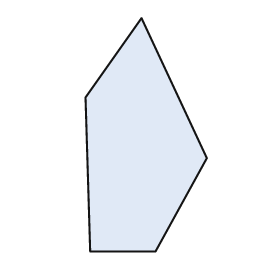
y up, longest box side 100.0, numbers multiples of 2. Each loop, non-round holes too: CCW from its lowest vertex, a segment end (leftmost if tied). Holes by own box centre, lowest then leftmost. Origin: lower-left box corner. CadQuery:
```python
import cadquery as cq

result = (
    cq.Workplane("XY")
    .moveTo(2.0, 0.0)
    .lineTo(30.0, 0.0)
    .lineTo(52.0, 40.0)
    .lineTo(24.0, 100.0)
    .lineTo(0.0, 66.0)
    .close()
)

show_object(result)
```